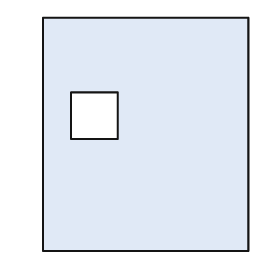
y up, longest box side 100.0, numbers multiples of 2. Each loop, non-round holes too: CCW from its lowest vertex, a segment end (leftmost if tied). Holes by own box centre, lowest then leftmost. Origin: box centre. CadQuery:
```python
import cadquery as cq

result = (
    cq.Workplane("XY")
    .moveTo(-44.0, -50.0)
    .lineTo(44.0, -50.0)
    .lineTo(44.0, 50.0)
    .lineTo(-44.0, 50.0)
    .close()
    .moveTo(-32.0, -2.0)
    .lineTo(-12.0, -2.0)
    .lineTo(-12.0, 18.0)
    .lineTo(-32.0, 18.0)
    .close()
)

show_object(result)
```